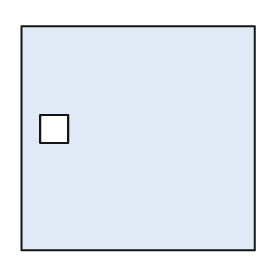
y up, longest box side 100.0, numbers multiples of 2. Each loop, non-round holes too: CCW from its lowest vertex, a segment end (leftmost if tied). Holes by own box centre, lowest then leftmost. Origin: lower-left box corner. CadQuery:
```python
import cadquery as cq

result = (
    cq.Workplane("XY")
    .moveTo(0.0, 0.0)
    .lineTo(100.0, 0.0)
    .lineTo(100.0, 96.0)
    .lineTo(0.0, 96.0)
    .close()
    .moveTo(8.0, 46.0)
    .lineTo(20.0, 46.0)
    .lineTo(20.0, 58.0)
    .lineTo(8.0, 58.0)
    .close()
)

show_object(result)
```